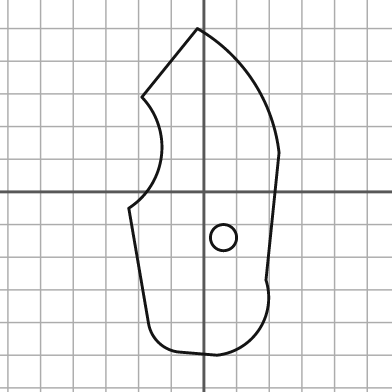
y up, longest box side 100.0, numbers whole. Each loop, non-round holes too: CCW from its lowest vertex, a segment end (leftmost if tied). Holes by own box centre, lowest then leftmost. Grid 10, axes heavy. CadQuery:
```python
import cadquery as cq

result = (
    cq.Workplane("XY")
    .moveTo(4.0, -50.0)
    .threePointArc((17.0, -42.0), (19.0, -27.0))
    .lineTo(23.0, 12.0)
    .threePointArc((15.0, 34.0), (-2.0, 50.0))
    .lineTo(-19.0, 29.0)
    .threePointArc((-13.0, 11.0), (-23.0, -5.0))
    .lineTo(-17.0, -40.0)
    .threePointArc((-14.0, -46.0), (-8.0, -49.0))
    .close()
    .moveTo(6.0, -14.0)
    .circle(4.0)
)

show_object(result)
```